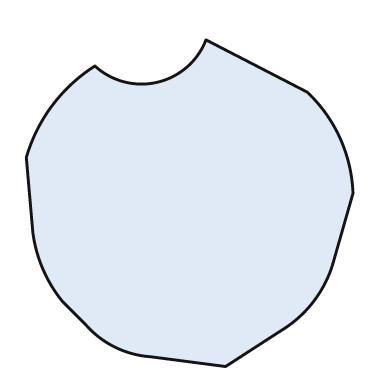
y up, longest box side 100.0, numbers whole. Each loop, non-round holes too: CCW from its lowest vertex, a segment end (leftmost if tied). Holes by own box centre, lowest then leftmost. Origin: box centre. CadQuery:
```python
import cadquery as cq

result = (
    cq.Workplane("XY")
    .moveTo(11.0, -50.0)
    .lineTo(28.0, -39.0)
    .threePointArc((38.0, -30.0), (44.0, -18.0))
    .lineTo(50.0, 3.0)
    .threePointArc((46.0, 20.0), (36.0, 34.0))
    .lineTo(5.0, 50.0)
    .threePointArc((-10.0, 37.0), (-29.0, 42.0))
    .threePointArc((-42.0, 30.0), (-50.0, 14.0))
    .lineTo(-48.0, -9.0)
    .threePointArc((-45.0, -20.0), (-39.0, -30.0))
    .lineTo(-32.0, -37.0)
    .threePointArc((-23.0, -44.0), (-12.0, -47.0))
    .close()
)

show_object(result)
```